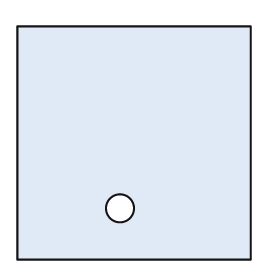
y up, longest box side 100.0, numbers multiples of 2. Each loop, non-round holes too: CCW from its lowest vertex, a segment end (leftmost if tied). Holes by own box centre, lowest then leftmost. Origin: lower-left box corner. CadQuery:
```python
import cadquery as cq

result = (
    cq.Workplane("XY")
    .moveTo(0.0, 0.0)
    .lineTo(100.0, 0.0)
    .lineTo(100.0, 100.0)
    .lineTo(0.0, 100.0)
    .close()
    .moveTo(44.0, 22.0)
    .circle(6.0)
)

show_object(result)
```